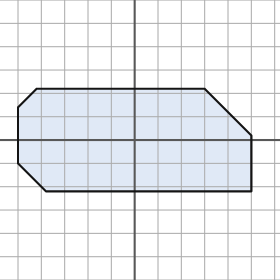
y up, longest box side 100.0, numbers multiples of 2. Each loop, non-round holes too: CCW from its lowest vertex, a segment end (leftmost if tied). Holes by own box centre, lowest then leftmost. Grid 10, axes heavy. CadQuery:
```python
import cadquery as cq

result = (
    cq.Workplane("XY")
    .moveTo(-38.0, -22.0)
    .lineTo(50.0, -22.0)
    .lineTo(50.0, 2.0)
    .lineTo(30.0, 22.0)
    .lineTo(-42.0, 22.0)
    .lineTo(-50.0, 14.0)
    .lineTo(-50.0, -10.0)
    .close()
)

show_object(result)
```